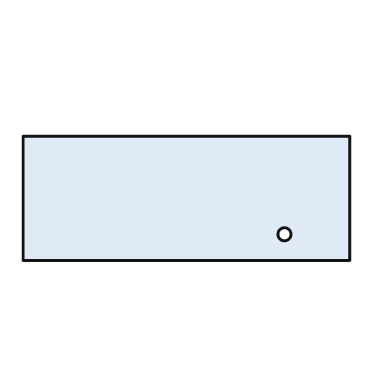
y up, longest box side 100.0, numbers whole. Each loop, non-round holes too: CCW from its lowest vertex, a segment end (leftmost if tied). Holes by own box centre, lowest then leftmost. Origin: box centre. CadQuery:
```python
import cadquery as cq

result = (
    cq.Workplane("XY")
    .moveTo(-50.0, -19.0)
    .lineTo(50.0, -19.0)
    .lineTo(50.0, 19.0)
    .lineTo(-50.0, 19.0)
    .close()
    .moveTo(30.0, -11.0)
    .circle(2.0)
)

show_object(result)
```